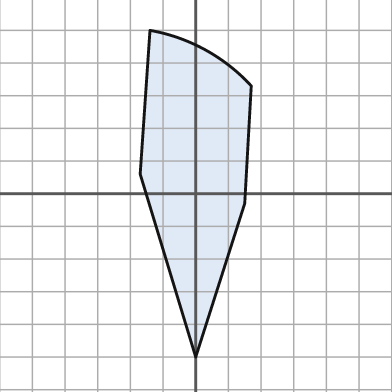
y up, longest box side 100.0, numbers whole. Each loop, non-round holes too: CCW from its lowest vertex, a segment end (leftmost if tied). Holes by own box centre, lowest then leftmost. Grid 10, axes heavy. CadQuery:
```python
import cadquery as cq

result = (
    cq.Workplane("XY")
    .moveTo(0.0, -50.0)
    .lineTo(15.0, -3.0)
    .lineTo(17.0, 33.0)
    .threePointArc((3.0, 44.0), (-14.0, 50.0))
    .lineTo(-17.0, 6.0)
    .close()
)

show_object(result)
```